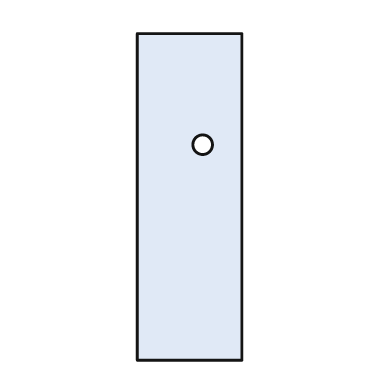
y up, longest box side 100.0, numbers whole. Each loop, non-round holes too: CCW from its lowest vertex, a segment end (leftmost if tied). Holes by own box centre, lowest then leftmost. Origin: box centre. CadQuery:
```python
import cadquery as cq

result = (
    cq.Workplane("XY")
    .moveTo(-16.0, -50.0)
    .lineTo(16.0, -50.0)
    .lineTo(16.0, 50.0)
    .lineTo(-16.0, 50.0)
    .close()
    .moveTo(4.0, 16.0)
    .circle(3.0)
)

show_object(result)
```